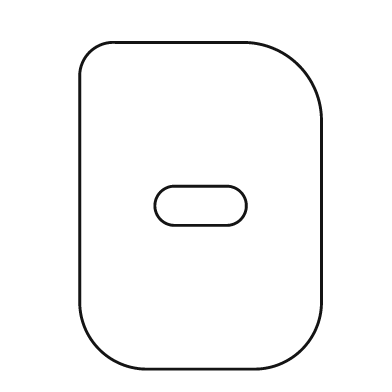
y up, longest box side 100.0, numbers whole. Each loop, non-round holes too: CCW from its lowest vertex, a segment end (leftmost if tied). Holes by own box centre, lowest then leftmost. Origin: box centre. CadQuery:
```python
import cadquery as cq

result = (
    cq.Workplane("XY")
    .moveTo(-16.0, -50.0)
    .lineTo(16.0, -50.0)
    .threePointArc((31.0, -44.0), (37.0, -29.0))
    .lineTo(37.0, 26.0)
    .threePointArc((30.0, 43.0), (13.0, 50.0))
    .lineTo(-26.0, 50.0)
    .threePointArc((-34.0, 47.0), (-37.0, 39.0))
    .lineTo(-37.0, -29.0)
    .threePointArc((-31.0, -44.0), (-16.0, -50.0))
    .close()
    .moveTo(-8.0, -6.0)
    .lineTo(8.0, -6.0)
    .threePointArc((14.0, 0.0), (8.0, 6.0))
    .lineTo(-8.0, 6.0)
    .threePointArc((-14.0, 0.0), (-8.0, -6.0))
    .close()
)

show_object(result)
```